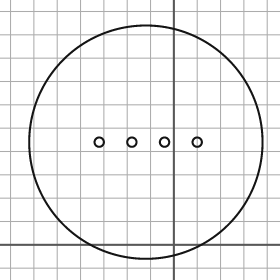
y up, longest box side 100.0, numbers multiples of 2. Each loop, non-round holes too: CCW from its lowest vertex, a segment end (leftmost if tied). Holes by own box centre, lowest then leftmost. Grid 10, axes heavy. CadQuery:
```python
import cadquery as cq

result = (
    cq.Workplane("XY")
    .moveTo(-12.0, 44.0)
    .circle(50.0)
    .moveTo(-32.0, 44.0)
    .circle(2.0)
    .moveTo(-18.0, 44.0)
    .circle(2.0)
    .moveTo(-4.0, 44.0)
    .circle(2.0)
    .moveTo(10.0, 44.0)
    .circle(2.0)
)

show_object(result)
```